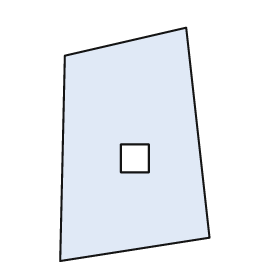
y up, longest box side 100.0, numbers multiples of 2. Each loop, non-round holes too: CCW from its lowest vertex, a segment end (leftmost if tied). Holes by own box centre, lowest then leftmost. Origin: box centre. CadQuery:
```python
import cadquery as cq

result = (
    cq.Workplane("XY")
    .moveTo(-32.0, -50.0)
    .lineTo(32.0, -40.0)
    .lineTo(22.0, 50.0)
    .lineTo(-30.0, 38.0)
    .close()
    .moveTo(-6.0, -12.0)
    .lineTo(6.0, -12.0)
    .lineTo(6.0, 0.0)
    .lineTo(-6.0, 0.0)
    .close()
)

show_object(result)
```